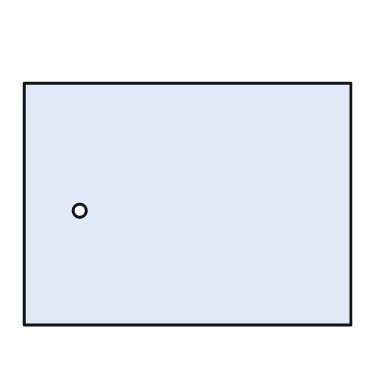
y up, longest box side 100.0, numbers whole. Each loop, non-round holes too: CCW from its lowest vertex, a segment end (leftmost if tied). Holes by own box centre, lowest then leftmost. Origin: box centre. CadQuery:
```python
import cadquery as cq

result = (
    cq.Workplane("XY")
    .moveTo(-50.0, -37.0)
    .lineTo(50.0, -37.0)
    .lineTo(50.0, 37.0)
    .lineTo(-50.0, 37.0)
    .close()
    .moveTo(-33.0, -2.0)
    .circle(2.0)
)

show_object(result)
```